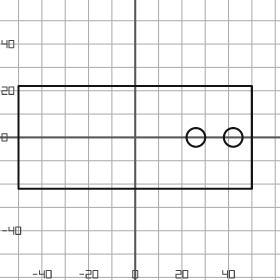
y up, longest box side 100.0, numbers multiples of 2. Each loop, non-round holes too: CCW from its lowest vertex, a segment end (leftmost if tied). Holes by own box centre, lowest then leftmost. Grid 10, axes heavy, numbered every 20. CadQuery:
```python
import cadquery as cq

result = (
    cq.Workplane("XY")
    .moveTo(-50.0, -22.0)
    .lineTo(50.0, -22.0)
    .lineTo(50.0, 22.0)
    .lineTo(-50.0, 22.0)
    .close()
    .moveTo(26.0, 0.0)
    .circle(4.0)
    .moveTo(42.0, 0.0)
    .circle(4.0)
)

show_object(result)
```